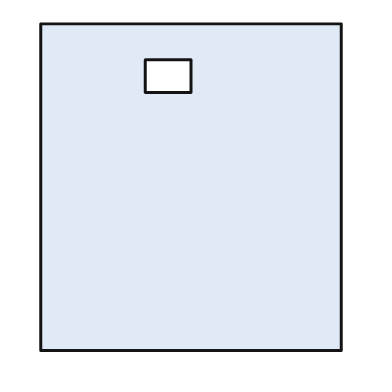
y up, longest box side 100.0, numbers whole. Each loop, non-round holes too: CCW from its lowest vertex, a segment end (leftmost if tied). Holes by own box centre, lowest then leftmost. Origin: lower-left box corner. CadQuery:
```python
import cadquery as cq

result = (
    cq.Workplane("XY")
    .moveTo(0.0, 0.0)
    .lineTo(92.0, 0.0)
    .lineTo(92.0, 100.0)
    .lineTo(0.0, 100.0)
    .close()
    .moveTo(32.0, 79.0)
    .lineTo(46.0, 79.0)
    .lineTo(46.0, 89.0)
    .lineTo(32.0, 89.0)
    .close()
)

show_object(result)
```